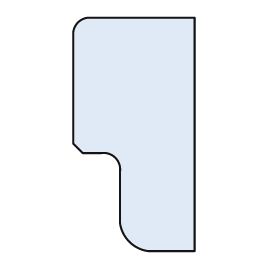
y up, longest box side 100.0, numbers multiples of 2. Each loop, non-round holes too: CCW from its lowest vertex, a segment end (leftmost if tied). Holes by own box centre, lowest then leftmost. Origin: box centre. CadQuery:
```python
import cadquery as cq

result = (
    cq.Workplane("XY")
    .moveTo(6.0, -50.0)
    .lineTo(26.0, -50.0)
    .lineTo(26.0, 50.0)
    .lineTo(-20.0, 50.0)
    .threePointArc((-24.0, 48.0), (-26.0, 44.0))
    .lineTo(-26.0, -4.0)
    .lineTo(-22.0, -8.0)
    .lineTo(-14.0, -8.0)
    .threePointArc((-8.0, -10.0), (-6.0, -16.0))
    .lineTo(-6.0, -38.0)
    .threePointArc((-2.0, -46.0), (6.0, -50.0))
    .close()
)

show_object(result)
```